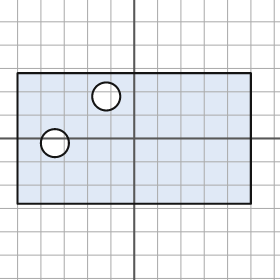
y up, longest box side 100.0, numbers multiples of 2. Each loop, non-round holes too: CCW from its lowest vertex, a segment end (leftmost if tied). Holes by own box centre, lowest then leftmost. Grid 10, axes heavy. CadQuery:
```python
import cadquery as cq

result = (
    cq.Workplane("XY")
    .moveTo(-50.0, -28.0)
    .lineTo(50.0, -28.0)
    .lineTo(50.0, 28.0)
    .lineTo(-50.0, 28.0)
    .close()
    .moveTo(-34.0, -2.0)
    .circle(6.0)
    .moveTo(-12.0, 18.0)
    .circle(6.0)
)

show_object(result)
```